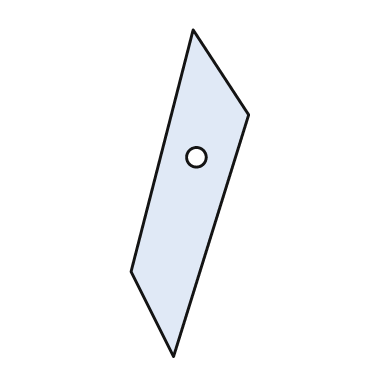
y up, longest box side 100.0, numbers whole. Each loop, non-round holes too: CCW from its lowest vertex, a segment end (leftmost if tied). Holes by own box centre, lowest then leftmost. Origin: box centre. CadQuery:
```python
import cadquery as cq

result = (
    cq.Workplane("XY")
    .moveTo(-5.0, -50.0)
    .lineTo(18.0, 24.0)
    .lineTo(1.0, 50.0)
    .lineTo(-18.0, -24.0)
    .close()
    .moveTo(2.0, 11.0)
    .circle(3.0)
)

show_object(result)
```